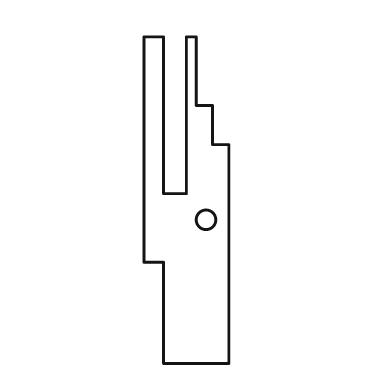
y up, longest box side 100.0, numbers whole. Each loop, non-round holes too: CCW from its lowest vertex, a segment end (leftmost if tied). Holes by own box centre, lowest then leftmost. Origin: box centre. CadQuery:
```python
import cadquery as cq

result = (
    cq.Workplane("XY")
    .moveTo(-7.0, -50.0)
    .lineTo(13.0, -50.0)
    .lineTo(13.0, 17.0)
    .lineTo(8.0, 17.0)
    .lineTo(8.0, 29.0)
    .lineTo(3.0, 29.0)
    .lineTo(3.0, 50.0)
    .lineTo(0.0, 50.0)
    .lineTo(0.0, 2.0)
    .lineTo(-7.0, 2.0)
    .lineTo(-7.0, 50.0)
    .lineTo(-13.0, 50.0)
    .lineTo(-13.0, -19.0)
    .lineTo(-7.0, -19.0)
    .close()
    .moveTo(6.0, -6.0)
    .circle(3.0)
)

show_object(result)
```